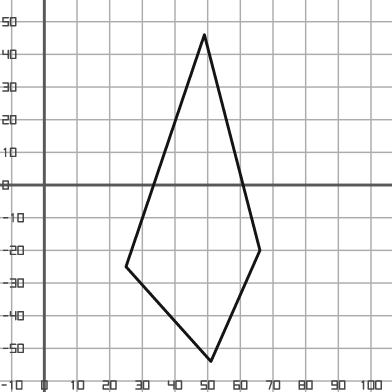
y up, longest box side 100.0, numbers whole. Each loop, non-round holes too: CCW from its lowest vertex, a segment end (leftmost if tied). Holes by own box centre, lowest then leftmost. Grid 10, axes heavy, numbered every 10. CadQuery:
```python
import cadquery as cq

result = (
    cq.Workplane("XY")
    .moveTo(51.0, -54.0)
    .lineTo(66.0, -20.0)
    .lineTo(49.0, 46.0)
    .lineTo(25.0, -25.0)
    .close()
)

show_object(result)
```